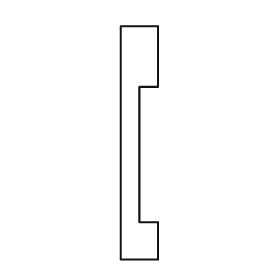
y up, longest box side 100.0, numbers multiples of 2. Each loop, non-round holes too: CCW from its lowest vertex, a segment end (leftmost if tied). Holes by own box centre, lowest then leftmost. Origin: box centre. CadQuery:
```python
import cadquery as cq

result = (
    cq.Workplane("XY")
    .moveTo(-8.0, -50.0)
    .lineTo(8.0, -50.0)
    .lineTo(8.0, -34.0)
    .lineTo(0.0, -34.0)
    .lineTo(0.0, 24.0)
    .lineTo(8.0, 24.0)
    .lineTo(8.0, 50.0)
    .lineTo(-8.0, 50.0)
    .close()
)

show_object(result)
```